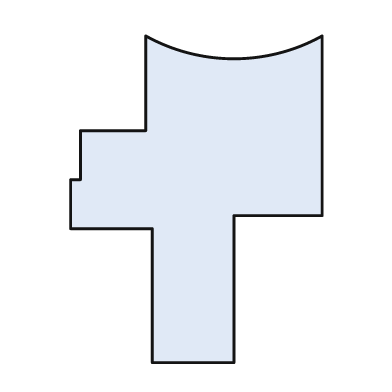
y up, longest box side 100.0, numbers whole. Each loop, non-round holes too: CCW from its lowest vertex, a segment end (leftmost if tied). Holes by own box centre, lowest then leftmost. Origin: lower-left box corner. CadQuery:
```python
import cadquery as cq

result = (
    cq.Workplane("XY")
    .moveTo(25.0, 0.0)
    .lineTo(50.0, 0.0)
    .lineTo(50.0, 45.0)
    .lineTo(77.0, 45.0)
    .lineTo(77.0, 100.0)
    .threePointArc((50.0, 93.0), (23.0, 100.0))
    .lineTo(23.0, 71.0)
    .lineTo(3.0, 71.0)
    .lineTo(3.0, 56.0)
    .lineTo(0.0, 56.0)
    .lineTo(0.0, 41.0)
    .lineTo(25.0, 41.0)
    .close()
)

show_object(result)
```